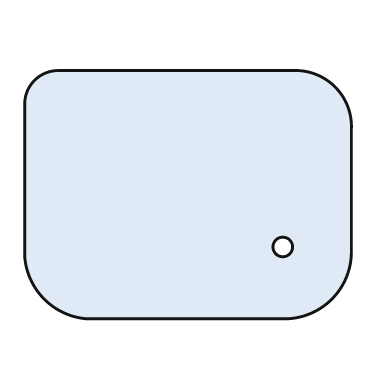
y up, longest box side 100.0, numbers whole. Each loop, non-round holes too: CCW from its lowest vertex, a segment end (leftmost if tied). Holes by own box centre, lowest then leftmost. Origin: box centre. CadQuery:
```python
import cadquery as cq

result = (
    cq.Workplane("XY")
    .moveTo(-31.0, -38.0)
    .lineTo(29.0, -38.0)
    .threePointArc((44.0, -32.0), (50.0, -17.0))
    .lineTo(50.0, 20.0)
    .threePointArc((45.0, 33.0), (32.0, 38.0))
    .lineTo(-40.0, 38.0)
    .threePointArc((-47.0, 35.0), (-50.0, 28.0))
    .lineTo(-50.0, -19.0)
    .threePointArc((-44.0, -32.0), (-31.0, -38.0))
    .close()
    .moveTo(29.0, -16.0)
    .circle(3.0)
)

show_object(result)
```